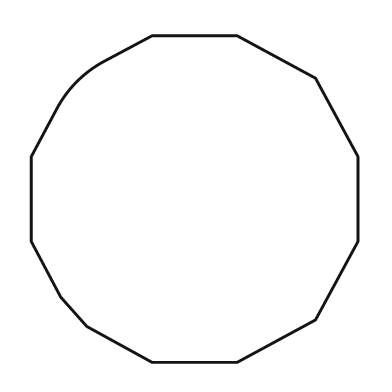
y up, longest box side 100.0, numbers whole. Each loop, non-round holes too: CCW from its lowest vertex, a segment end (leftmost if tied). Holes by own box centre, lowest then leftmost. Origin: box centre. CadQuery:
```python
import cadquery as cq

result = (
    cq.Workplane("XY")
    .moveTo(-13.0, -50.0)
    .lineTo(13.0, -50.0)
    .lineTo(37.0, -37.0)
    .lineTo(50.0, -13.0)
    .lineTo(50.0, 13.0)
    .lineTo(37.0, 37.0)
    .lineTo(13.0, 50.0)
    .lineTo(-13.0, 50.0)
    .lineTo(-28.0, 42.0)
    .threePointArc((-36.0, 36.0), (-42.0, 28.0))
    .lineTo(-50.0, 13.0)
    .lineTo(-50.0, -13.0)
    .lineTo(-41.0, -30.0)
    .lineTo(-33.0, -39.0)
    .close()
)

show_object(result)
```